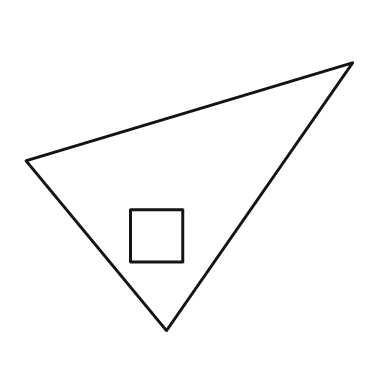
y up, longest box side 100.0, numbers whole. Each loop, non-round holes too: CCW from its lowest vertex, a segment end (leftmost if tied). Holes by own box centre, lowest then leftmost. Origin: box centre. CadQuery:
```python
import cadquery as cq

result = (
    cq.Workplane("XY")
    .moveTo(-7.0, -41.0)
    .lineTo(50.0, 41.0)
    .lineTo(-50.0, 11.0)
    .close()
    .moveTo(-18.0, -20.0)
    .lineTo(-2.0, -20.0)
    .lineTo(-2.0, -4.0)
    .lineTo(-18.0, -4.0)
    .close()
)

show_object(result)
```